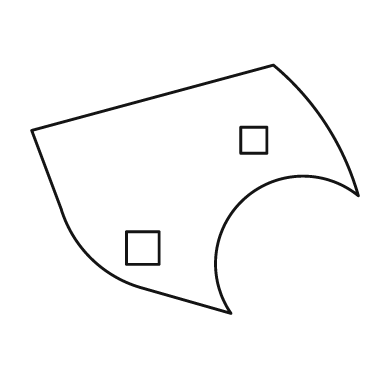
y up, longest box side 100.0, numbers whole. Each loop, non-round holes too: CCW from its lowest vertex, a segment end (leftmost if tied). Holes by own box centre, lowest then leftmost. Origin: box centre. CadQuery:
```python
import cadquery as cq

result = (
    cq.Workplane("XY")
    .moveTo(11.0, -38.0)
    .threePointArc((15.0, -3.0), (50.0, -2.0))
    .threePointArc((40.0, 20.0), (24.0, 38.0))
    .lineTo(-50.0, 18.0)
    .lineTo(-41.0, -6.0)
    .threePointArc((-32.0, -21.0), (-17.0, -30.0))
    .close()
    .moveTo(-21.0, -23.0)
    .lineTo(-11.0, -23.0)
    .lineTo(-11.0, -13.0)
    .lineTo(-21.0, -13.0)
    .close()
    .moveTo(14.0, 11.0)
    .lineTo(22.0, 11.0)
    .lineTo(22.0, 19.0)
    .lineTo(14.0, 19.0)
    .close()
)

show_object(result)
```